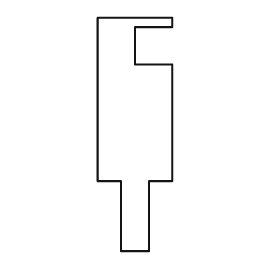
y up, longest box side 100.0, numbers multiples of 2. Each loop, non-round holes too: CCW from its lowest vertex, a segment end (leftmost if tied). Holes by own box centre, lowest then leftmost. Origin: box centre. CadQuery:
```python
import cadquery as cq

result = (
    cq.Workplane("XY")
    .moveTo(-6.0, -50.0)
    .lineTo(6.0, -50.0)
    .lineTo(6.0, -20.0)
    .lineTo(16.0, -20.0)
    .lineTo(16.0, 30.0)
    .lineTo(0.0, 30.0)
    .lineTo(0.0, 46.0)
    .lineTo(16.0, 46.0)
    .lineTo(16.0, 50.0)
    .lineTo(-16.0, 50.0)
    .lineTo(-16.0, -20.0)
    .lineTo(-6.0, -20.0)
    .close()
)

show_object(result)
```